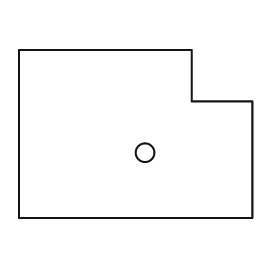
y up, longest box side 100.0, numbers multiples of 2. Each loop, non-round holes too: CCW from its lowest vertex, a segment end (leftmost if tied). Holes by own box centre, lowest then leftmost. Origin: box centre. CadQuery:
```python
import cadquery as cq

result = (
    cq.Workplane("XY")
    .moveTo(-50.0, -36.0)
    .lineTo(50.0, -36.0)
    .lineTo(50.0, 14.0)
    .lineTo(24.0, 14.0)
    .lineTo(24.0, 36.0)
    .lineTo(-50.0, 36.0)
    .close()
    .moveTo(4.0, -8.0)
    .circle(4.0)
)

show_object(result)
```